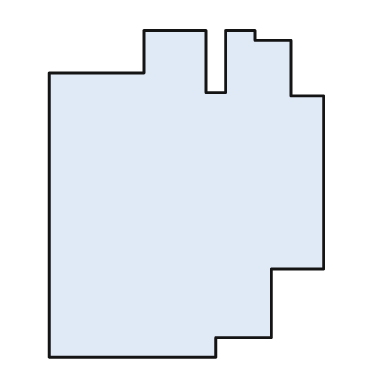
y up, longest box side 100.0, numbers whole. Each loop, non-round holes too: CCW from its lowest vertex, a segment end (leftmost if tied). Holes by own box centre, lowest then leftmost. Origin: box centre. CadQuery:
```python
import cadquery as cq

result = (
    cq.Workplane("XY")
    .moveTo(-42.0, -50.0)
    .lineTo(9.0, -50.0)
    .lineTo(9.0, -44.0)
    .lineTo(26.0, -44.0)
    .lineTo(26.0, -23.0)
    .lineTo(42.0, -23.0)
    .lineTo(42.0, 30.0)
    .lineTo(32.0, 30.0)
    .lineTo(32.0, 47.0)
    .lineTo(21.0, 47.0)
    .lineTo(21.0, 50.0)
    .lineTo(12.0, 50.0)
    .lineTo(12.0, 31.0)
    .lineTo(6.0, 31.0)
    .lineTo(6.0, 50.0)
    .lineTo(-13.0, 50.0)
    .lineTo(-13.0, 37.0)
    .lineTo(-42.0, 37.0)
    .close()
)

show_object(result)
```